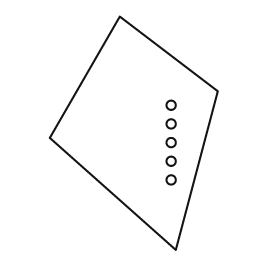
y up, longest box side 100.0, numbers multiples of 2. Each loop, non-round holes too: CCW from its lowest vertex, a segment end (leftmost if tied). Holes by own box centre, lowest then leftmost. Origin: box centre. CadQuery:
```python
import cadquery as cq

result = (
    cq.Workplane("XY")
    .moveTo(18.0, -50.0)
    .lineTo(36.0, 18.0)
    .lineTo(-6.0, 50.0)
    .lineTo(-36.0, -2.0)
    .close()
    .moveTo(16.0, -20.0)
    .circle(2.0)
    .moveTo(16.0, -12.0)
    .circle(2.0)
    .moveTo(16.0, -4.0)
    .circle(2.0)
    .moveTo(16.0, 4.0)
    .circle(2.0)
    .moveTo(16.0, 12.0)
    .circle(2.0)
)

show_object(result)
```